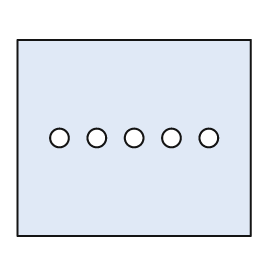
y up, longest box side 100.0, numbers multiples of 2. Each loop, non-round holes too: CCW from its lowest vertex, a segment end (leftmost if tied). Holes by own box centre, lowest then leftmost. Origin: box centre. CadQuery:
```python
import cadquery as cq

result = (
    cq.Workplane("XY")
    .moveTo(-50.0, -42.0)
    .lineTo(50.0, -42.0)
    .lineTo(50.0, 42.0)
    .lineTo(-50.0, 42.0)
    .close()
    .moveTo(-32.0, 0.0)
    .circle(4.0)
    .moveTo(-16.0, 0.0)
    .circle(4.0)
    .moveTo(0.0, 0.0)
    .circle(4.0)
    .moveTo(16.0, 0.0)
    .circle(4.0)
    .moveTo(32.0, 0.0)
    .circle(4.0)
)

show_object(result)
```